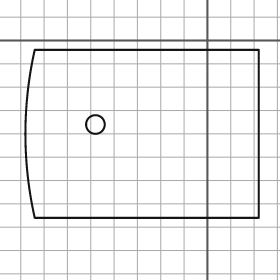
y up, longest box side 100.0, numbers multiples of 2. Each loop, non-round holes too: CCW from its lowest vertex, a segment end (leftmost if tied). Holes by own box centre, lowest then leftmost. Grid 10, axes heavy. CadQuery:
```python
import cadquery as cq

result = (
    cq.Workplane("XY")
    .moveTo(-74.0, -76.0)
    .lineTo(22.0, -76.0)
    .lineTo(22.0, -4.0)
    .lineTo(-74.0, -4.0)
    .threePointArc((-78.0, -40.0), (-74.0, -76.0))
    .close()
    .moveTo(-48.0, -36.0)
    .circle(4.0)
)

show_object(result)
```